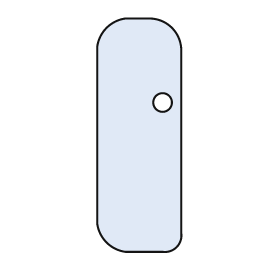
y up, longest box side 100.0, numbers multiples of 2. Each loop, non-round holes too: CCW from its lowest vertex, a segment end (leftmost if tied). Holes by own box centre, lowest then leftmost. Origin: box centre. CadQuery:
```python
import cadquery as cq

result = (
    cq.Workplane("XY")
    .moveTo(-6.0, -50.0)
    .lineTo(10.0, -50.0)
    .threePointArc((16.0, -48.0), (18.0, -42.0))
    .lineTo(18.0, 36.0)
    .threePointArc((14.0, 46.0), (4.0, 50.0))
    .lineTo(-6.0, 50.0)
    .threePointArc((-14.0, 46.0), (-18.0, 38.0))
    .lineTo(-18.0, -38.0)
    .threePointArc((-14.0, -46.0), (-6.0, -50.0))
    .close()
    .moveTo(10.0, 14.0)
    .circle(4.0)
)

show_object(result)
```